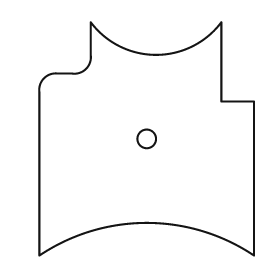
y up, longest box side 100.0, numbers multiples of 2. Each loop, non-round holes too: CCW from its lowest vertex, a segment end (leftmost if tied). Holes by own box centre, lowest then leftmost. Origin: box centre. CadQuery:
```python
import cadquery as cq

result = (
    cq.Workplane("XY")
    .moveTo(-46.0, -50.0)
    .threePointArc((0.0, -36.0), (46.0, -50.0))
    .lineTo(46.0, 16.0)
    .lineTo(32.0, 16.0)
    .lineTo(32.0, 50.0)
    .threePointArc((4.0, 36.0), (-24.0, 50.0))
    .lineTo(-24.0, 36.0)
    .threePointArc((-26.0, 30.0), (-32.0, 28.0))
    .lineTo(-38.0, 28.0)
    .threePointArc((-44.0, 26.0), (-46.0, 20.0))
    .close()
    .moveTo(0.0, 0.0)
    .circle(4.0)
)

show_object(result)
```